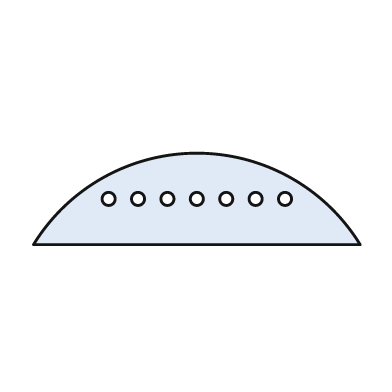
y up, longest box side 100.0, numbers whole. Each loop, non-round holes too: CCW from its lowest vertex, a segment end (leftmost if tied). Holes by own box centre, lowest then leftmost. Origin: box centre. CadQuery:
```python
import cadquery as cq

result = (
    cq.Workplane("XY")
    .moveTo(-50.0, -14.0)
    .lineTo(50.0, -14.0)
    .threePointArc((0.0, 14.0), (-50.0, -14.0))
    .close()
    .moveTo(-27.0, 0.0)
    .circle(2.0)
    .moveTo(-18.0, 0.0)
    .circle(2.0)
    .moveTo(-9.0, 0.0)
    .circle(2.0)
    .moveTo(0.0, 0.0)
    .circle(2.0)
    .moveTo(9.0, 0.0)
    .circle(2.0)
    .moveTo(18.0, 0.0)
    .circle(2.0)
    .moveTo(27.0, 0.0)
    .circle(2.0)
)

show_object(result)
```